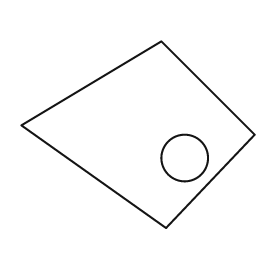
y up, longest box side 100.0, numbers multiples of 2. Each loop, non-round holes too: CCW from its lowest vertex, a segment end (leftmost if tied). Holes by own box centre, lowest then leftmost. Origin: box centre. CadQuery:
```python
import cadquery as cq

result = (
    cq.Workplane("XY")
    .moveTo(12.0, -40.0)
    .lineTo(50.0, 0.0)
    .lineTo(10.0, 40.0)
    .lineTo(-50.0, 4.0)
    .close()
    .moveTo(20.0, -10.0)
    .circle(10.0)
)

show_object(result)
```